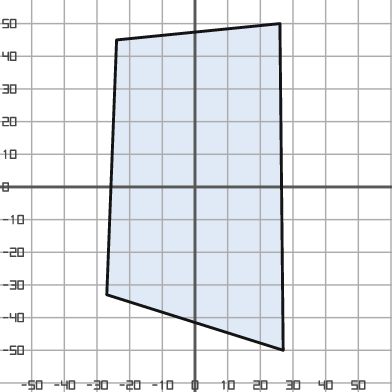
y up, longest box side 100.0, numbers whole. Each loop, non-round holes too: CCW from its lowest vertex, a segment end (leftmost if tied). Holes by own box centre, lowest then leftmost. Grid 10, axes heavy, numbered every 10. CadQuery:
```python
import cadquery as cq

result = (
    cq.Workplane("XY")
    .moveTo(27.0, -50.0)
    .lineTo(26.0, 50.0)
    .lineTo(-24.0, 45.0)
    .lineTo(-27.0, -33.0)
    .close()
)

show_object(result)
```